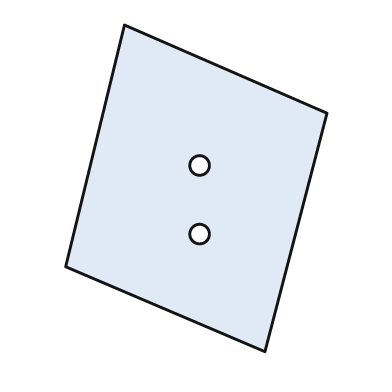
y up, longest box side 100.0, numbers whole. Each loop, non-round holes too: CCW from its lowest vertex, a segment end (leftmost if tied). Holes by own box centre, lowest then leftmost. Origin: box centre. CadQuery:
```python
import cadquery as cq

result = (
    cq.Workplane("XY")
    .moveTo(21.0, -50.0)
    .lineTo(40.0, 23.0)
    .lineTo(-22.0, 50.0)
    .lineTo(-40.0, -24.0)
    .close()
    .moveTo(1.0, -14.0)
    .circle(3.0)
    .moveTo(1.0, 7.0)
    .circle(3.0)
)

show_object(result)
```